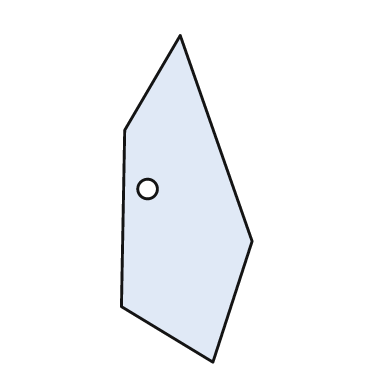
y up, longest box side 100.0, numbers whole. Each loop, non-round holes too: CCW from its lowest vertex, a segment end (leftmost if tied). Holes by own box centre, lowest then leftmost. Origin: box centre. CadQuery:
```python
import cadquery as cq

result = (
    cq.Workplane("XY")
    .moveTo(8.0, -50.0)
    .lineTo(20.0, -13.0)
    .lineTo(-2.0, 50.0)
    .lineTo(-19.0, 21.0)
    .lineTo(-20.0, -33.0)
    .close()
    .moveTo(-12.0, 3.0)
    .circle(3.0)
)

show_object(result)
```